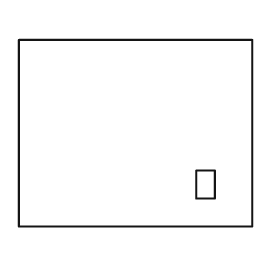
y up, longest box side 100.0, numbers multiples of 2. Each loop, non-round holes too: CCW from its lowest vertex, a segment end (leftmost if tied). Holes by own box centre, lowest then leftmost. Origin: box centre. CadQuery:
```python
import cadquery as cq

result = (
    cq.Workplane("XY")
    .moveTo(-50.0, -40.0)
    .lineTo(50.0, -40.0)
    .lineTo(50.0, 40.0)
    .lineTo(-50.0, 40.0)
    .close()
    .moveTo(26.0, -28.0)
    .lineTo(34.0, -28.0)
    .lineTo(34.0, -16.0)
    .lineTo(26.0, -16.0)
    .close()
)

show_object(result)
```